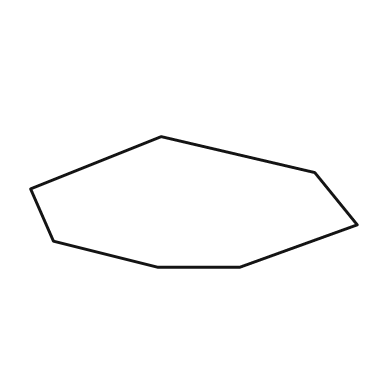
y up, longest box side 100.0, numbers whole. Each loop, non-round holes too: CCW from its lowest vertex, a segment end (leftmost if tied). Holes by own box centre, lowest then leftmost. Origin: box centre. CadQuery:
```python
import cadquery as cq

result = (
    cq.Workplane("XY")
    .moveTo(-11.0, -20.0)
    .lineTo(14.0, -20.0)
    .lineTo(50.0, -7.0)
    .lineTo(37.0, 9.0)
    .lineTo(-10.0, 20.0)
    .lineTo(-50.0, 4.0)
    .lineTo(-43.0, -12.0)
    .close()
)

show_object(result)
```